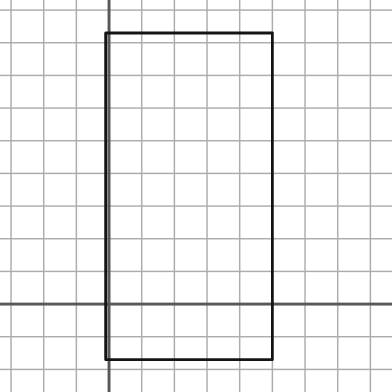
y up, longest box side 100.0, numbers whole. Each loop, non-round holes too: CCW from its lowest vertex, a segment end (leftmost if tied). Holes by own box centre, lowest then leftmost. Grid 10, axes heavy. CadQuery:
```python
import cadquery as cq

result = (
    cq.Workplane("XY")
    .moveTo(-1.0, -17.0)
    .lineTo(50.0, -17.0)
    .lineTo(50.0, 83.0)
    .lineTo(-1.0, 83.0)
    .close()
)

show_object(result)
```